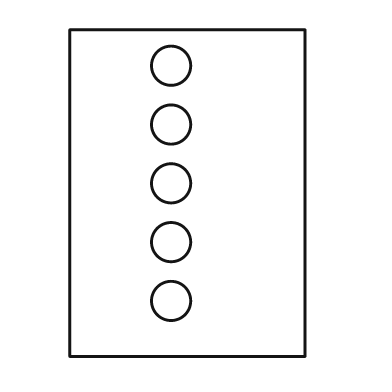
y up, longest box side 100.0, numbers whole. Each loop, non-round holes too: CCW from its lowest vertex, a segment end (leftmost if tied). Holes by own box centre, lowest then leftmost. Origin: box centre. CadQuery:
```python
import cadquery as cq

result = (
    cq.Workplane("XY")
    .moveTo(-36.0, -50.0)
    .lineTo(36.0, -50.0)
    .lineTo(36.0, 50.0)
    .lineTo(-36.0, 50.0)
    .close()
    .moveTo(-5.0, -33.0)
    .circle(6.0)
    .moveTo(-5.0, -15.0)
    .circle(6.0)
    .moveTo(-5.0, 3.0)
    .circle(6.0)
    .moveTo(-5.0, 21.0)
    .circle(6.0)
    .moveTo(-5.0, 39.0)
    .circle(6.0)
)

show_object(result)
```